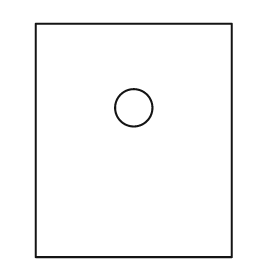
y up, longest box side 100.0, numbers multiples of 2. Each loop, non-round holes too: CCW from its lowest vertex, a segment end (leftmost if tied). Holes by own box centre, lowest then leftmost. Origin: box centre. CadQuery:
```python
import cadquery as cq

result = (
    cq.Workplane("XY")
    .moveTo(-42.0, -50.0)
    .lineTo(42.0, -50.0)
    .lineTo(42.0, 50.0)
    .lineTo(-42.0, 50.0)
    .close()
    .moveTo(0.0, 14.0)
    .circle(8.0)
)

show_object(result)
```